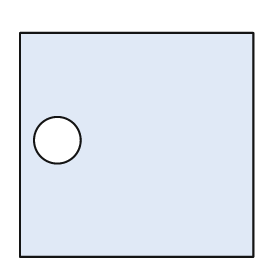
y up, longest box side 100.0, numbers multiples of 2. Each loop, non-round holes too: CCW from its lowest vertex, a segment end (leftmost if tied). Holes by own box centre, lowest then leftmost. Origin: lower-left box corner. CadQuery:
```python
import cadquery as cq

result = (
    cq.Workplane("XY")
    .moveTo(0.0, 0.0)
    .lineTo(100.0, 0.0)
    .lineTo(100.0, 96.0)
    .lineTo(0.0, 96.0)
    .close()
    .moveTo(16.0, 50.0)
    .circle(10.0)
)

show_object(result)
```